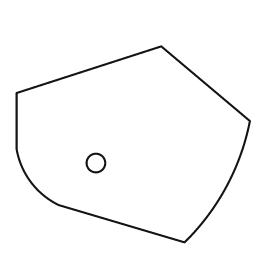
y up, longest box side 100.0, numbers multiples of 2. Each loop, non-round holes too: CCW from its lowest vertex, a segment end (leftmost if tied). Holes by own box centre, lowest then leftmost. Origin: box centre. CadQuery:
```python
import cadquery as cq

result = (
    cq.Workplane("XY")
    .moveTo(22.0, -42.0)
    .threePointArc((40.0, -18.0), (50.0, 10.0))
    .lineTo(12.0, 42.0)
    .lineTo(-50.0, 22.0)
    .lineTo(-50.0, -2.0)
    .threePointArc((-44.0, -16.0), (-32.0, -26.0))
    .close()
    .moveTo(-16.0, -8.0)
    .circle(4.0)
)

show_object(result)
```